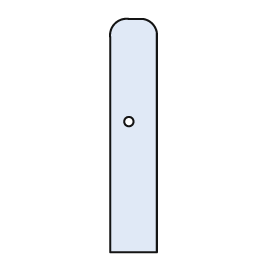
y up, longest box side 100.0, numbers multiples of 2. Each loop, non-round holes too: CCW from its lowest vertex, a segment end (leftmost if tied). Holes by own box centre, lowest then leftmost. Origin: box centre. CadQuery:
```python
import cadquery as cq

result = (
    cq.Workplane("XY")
    .moveTo(-10.0, -50.0)
    .lineTo(10.0, -50.0)
    .lineTo(10.0, 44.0)
    .threePointArc((8.0, 48.0), (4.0, 50.0))
    .lineTo(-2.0, 50.0)
    .threePointArc((-8.0, 48.0), (-10.0, 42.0))
    .close()
    .moveTo(-2.0, 6.0)
    .circle(2.0)
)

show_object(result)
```